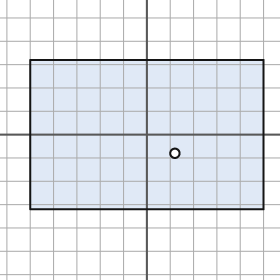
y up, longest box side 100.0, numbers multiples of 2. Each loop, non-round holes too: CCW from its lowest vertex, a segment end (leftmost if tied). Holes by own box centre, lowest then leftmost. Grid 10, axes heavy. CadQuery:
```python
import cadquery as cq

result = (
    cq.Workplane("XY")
    .moveTo(-50.0, -32.0)
    .lineTo(50.0, -32.0)
    .lineTo(50.0, 32.0)
    .lineTo(-50.0, 32.0)
    .close()
    .moveTo(12.0, -8.0)
    .circle(2.0)
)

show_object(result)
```